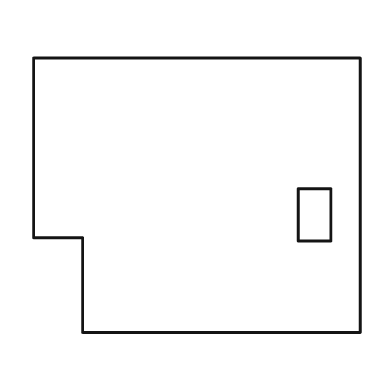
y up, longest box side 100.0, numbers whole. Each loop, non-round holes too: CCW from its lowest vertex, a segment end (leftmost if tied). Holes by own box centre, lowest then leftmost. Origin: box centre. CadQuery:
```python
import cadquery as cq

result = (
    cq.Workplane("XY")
    .moveTo(-35.0, -42.0)
    .lineTo(50.0, -42.0)
    .lineTo(50.0, 42.0)
    .lineTo(-50.0, 42.0)
    .lineTo(-50.0, -13.0)
    .lineTo(-35.0, -13.0)
    .close()
    .moveTo(31.0, -14.0)
    .lineTo(41.0, -14.0)
    .lineTo(41.0, 2.0)
    .lineTo(31.0, 2.0)
    .close()
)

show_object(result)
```